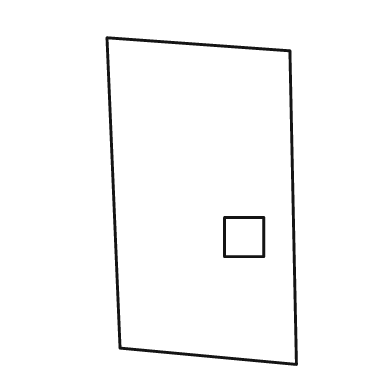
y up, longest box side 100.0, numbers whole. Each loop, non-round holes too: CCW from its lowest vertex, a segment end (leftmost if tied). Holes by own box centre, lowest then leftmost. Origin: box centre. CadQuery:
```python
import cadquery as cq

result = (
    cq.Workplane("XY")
    .moveTo(29.0, -50.0)
    .lineTo(27.0, 46.0)
    .lineTo(-29.0, 50.0)
    .lineTo(-25.0, -45.0)
    .close()
    .moveTo(7.0, -17.0)
    .lineTo(19.0, -17.0)
    .lineTo(19.0, -5.0)
    .lineTo(7.0, -5.0)
    .close()
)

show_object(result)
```